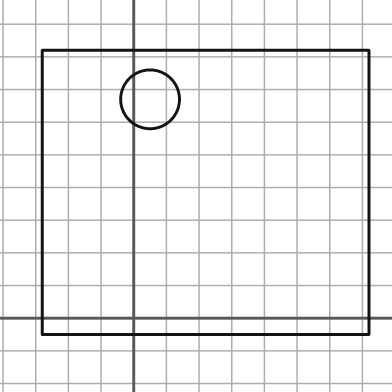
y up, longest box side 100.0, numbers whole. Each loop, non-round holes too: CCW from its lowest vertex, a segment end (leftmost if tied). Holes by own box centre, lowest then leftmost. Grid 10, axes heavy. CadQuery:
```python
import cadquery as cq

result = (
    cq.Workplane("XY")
    .moveTo(-28.0, -5.0)
    .lineTo(72.0, -5.0)
    .lineTo(72.0, 82.0)
    .lineTo(-28.0, 82.0)
    .close()
    .moveTo(5.0, 67.0)
    .circle(9.0)
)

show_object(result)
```